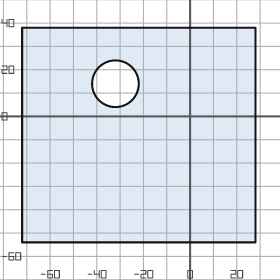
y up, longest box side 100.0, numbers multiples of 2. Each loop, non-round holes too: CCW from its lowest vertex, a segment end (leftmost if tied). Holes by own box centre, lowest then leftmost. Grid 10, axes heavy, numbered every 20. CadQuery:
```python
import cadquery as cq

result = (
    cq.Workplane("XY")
    .moveTo(-72.0, -54.0)
    .lineTo(28.0, -54.0)
    .lineTo(28.0, 38.0)
    .lineTo(-72.0, 38.0)
    .close()
    .moveTo(-32.0, 14.0)
    .circle(10.0)
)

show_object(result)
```